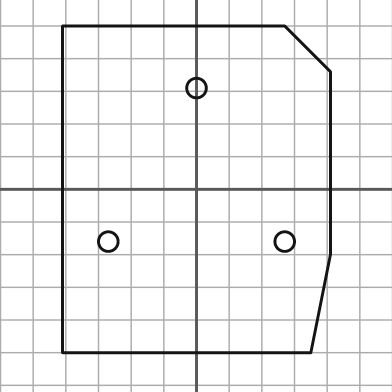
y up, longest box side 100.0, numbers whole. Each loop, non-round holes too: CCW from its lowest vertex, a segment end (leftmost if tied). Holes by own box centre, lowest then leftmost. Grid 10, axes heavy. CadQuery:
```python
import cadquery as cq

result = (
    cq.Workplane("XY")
    .moveTo(-41.0, -50.0)
    .lineTo(35.0, -50.0)
    .lineTo(41.0, -20.0)
    .lineTo(41.0, 36.0)
    .lineTo(27.0, 50.0)
    .lineTo(-41.0, 50.0)
    .close()
    .moveTo(-27.0, -16.0)
    .circle(3.0)
    .moveTo(27.0, -16.0)
    .circle(3.0)
    .moveTo(0.0, 31.0)
    .circle(3.0)
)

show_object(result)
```